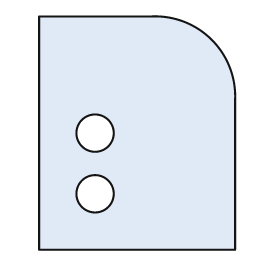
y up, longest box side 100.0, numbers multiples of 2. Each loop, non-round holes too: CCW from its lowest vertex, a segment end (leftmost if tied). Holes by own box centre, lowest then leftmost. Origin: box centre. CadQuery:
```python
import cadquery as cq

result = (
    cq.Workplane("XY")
    .moveTo(-42.0, -50.0)
    .lineTo(42.0, -50.0)
    .lineTo(42.0, 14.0)
    .threePointArc((32.0, 40.0), (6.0, 50.0))
    .lineTo(-42.0, 50.0)
    .close()
    .moveTo(-18.0, -26.0)
    .circle(8.0)
    .moveTo(-18.0, 0.0)
    .circle(8.0)
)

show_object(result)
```